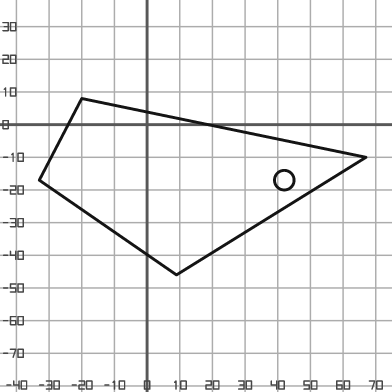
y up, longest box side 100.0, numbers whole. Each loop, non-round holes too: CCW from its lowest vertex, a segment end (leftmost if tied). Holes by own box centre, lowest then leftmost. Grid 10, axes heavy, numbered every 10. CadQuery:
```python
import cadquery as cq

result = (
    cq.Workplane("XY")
    .moveTo(9.0, -46.0)
    .lineTo(67.0, -10.0)
    .lineTo(-20.0, 8.0)
    .lineTo(-33.0, -17.0)
    .close()
    .moveTo(42.0, -17.0)
    .circle(3.0)
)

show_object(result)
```